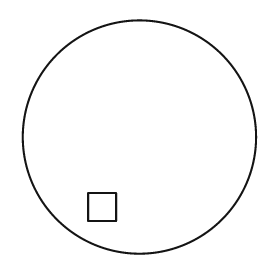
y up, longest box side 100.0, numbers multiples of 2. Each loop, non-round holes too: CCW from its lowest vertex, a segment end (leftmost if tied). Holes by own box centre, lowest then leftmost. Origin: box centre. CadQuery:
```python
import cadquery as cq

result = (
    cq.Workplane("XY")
    .moveTo(0.0, 0.0)
    .circle(50.0)
    .moveTo(-22.0, -36.0)
    .lineTo(-10.0, -36.0)
    .lineTo(-10.0, -24.0)
    .lineTo(-22.0, -24.0)
    .close()
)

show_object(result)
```